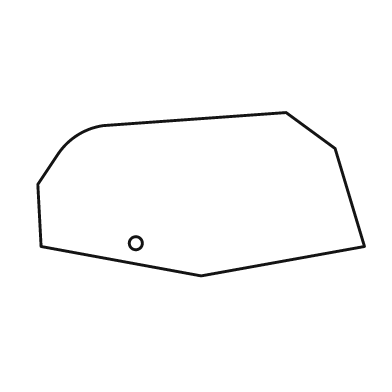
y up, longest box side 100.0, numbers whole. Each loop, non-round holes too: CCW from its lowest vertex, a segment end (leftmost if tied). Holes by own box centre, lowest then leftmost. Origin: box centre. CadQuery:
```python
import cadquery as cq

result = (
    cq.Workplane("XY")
    .moveTo(0.0, -25.0)
    .lineTo(50.0, -16.0)
    .lineTo(41.0, 14.0)
    .lineTo(26.0, 25.0)
    .lineTo(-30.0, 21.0)
    .threePointArc((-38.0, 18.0), (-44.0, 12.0))
    .lineTo(-50.0, 3.0)
    .lineTo(-49.0, -16.0)
    .close()
    .moveTo(-20.0, -15.0)
    .circle(2.0)
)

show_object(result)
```